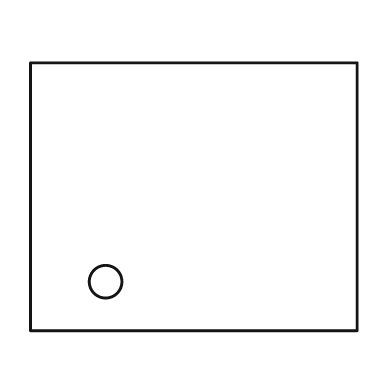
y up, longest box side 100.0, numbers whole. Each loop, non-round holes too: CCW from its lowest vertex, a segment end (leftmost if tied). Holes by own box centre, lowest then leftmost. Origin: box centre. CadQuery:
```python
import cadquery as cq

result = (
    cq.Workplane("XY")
    .moveTo(-50.0, -41.0)
    .lineTo(50.0, -41.0)
    .lineTo(50.0, 41.0)
    .lineTo(-50.0, 41.0)
    .close()
    .moveTo(-27.0, -26.0)
    .circle(5.0)
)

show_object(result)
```